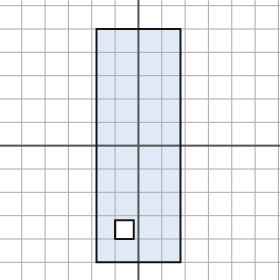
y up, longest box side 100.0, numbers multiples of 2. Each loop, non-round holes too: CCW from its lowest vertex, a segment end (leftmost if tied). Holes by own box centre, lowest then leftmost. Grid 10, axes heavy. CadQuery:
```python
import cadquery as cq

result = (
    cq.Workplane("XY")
    .moveTo(-18.0, -50.0)
    .lineTo(18.0, -50.0)
    .lineTo(18.0, 50.0)
    .lineTo(-18.0, 50.0)
    .close()
    .moveTo(-10.0, -40.0)
    .lineTo(-2.0, -40.0)
    .lineTo(-2.0, -32.0)
    .lineTo(-10.0, -32.0)
    .close()
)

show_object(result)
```